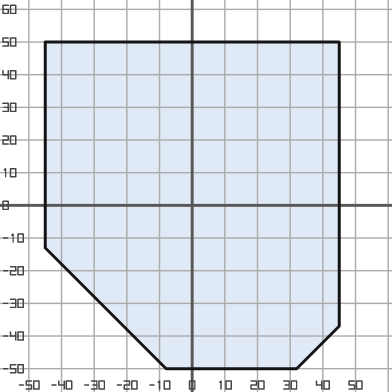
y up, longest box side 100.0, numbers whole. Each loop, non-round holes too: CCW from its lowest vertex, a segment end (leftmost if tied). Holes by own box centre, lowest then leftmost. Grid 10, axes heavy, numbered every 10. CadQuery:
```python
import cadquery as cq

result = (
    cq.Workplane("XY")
    .moveTo(-8.0, -50.0)
    .lineTo(32.0, -50.0)
    .lineTo(45.0, -37.0)
    .lineTo(45.0, 50.0)
    .lineTo(-45.0, 50.0)
    .lineTo(-45.0, -13.0)
    .close()
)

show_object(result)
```